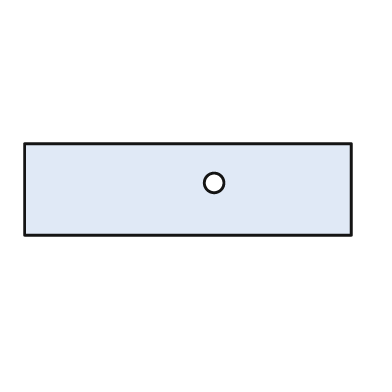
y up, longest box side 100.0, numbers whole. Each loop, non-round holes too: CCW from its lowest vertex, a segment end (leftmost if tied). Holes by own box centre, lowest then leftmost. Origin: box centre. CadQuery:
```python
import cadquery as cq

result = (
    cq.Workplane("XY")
    .moveTo(-50.0, -14.0)
    .lineTo(50.0, -14.0)
    .lineTo(50.0, 14.0)
    .lineTo(-50.0, 14.0)
    .close()
    .moveTo(8.0, 2.0)
    .circle(3.0)
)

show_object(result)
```